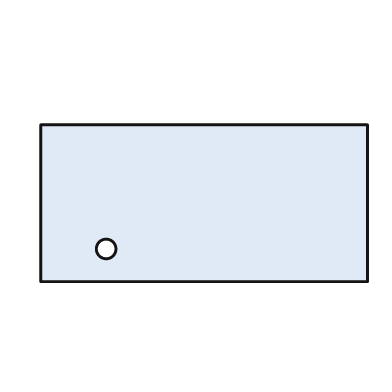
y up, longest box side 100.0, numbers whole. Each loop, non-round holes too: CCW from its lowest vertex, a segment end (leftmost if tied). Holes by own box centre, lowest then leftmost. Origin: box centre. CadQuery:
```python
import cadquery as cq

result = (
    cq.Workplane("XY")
    .moveTo(-50.0, -24.0)
    .lineTo(50.0, -24.0)
    .lineTo(50.0, 24.0)
    .lineTo(-50.0, 24.0)
    .close()
    .moveTo(-30.0, -14.0)
    .circle(3.0)
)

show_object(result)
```